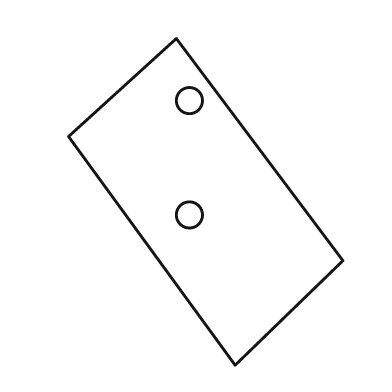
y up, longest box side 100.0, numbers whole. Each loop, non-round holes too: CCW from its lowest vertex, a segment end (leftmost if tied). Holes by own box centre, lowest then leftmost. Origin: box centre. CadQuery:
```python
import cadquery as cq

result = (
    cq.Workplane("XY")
    .moveTo(9.0, -50.0)
    .lineTo(42.0, -18.0)
    .lineTo(-9.0, 50.0)
    .lineTo(-42.0, 20.0)
    .close()
    .moveTo(-5.0, -4.0)
    .circle(4.0)
    .moveTo(-5.0, 31.0)
    .circle(4.0)
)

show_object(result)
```